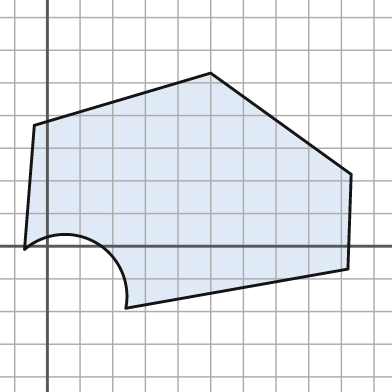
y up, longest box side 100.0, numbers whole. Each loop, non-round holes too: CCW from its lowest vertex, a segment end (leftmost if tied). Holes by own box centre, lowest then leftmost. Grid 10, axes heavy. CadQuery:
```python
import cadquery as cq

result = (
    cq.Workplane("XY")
    .moveTo(24.0, -19.0)
    .lineTo(92.0, -7.0)
    .lineTo(93.0, 22.0)
    .lineTo(50.0, 53.0)
    .lineTo(-4.0, 37.0)
    .lineTo(-7.0, -1.0)
    .threePointArc((15.0, 1.0), (24.0, -19.0))
    .close()
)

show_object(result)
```